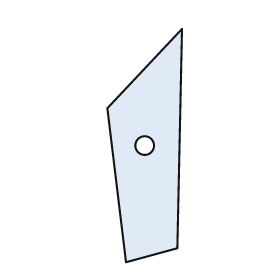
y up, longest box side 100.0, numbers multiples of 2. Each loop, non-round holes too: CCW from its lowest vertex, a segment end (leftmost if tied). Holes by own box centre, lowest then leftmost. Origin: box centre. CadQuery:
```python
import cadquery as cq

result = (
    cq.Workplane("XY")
    .moveTo(-8.0, -50.0)
    .lineTo(14.0, -44.0)
    .lineTo(16.0, 50.0)
    .lineTo(-16.0, 16.0)
    .close()
    .moveTo(0.0, 0.0)
    .circle(4.0)
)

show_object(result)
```